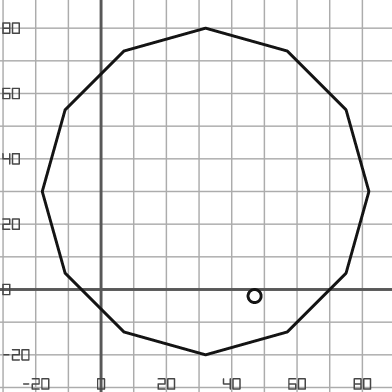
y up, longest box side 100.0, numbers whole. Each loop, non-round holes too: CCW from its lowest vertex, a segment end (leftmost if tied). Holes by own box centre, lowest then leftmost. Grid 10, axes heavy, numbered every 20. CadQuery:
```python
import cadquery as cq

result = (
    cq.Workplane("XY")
    .moveTo(32.0, -20.0)
    .lineTo(57.0, -13.0)
    .lineTo(75.0, 5.0)
    .lineTo(82.0, 30.0)
    .lineTo(75.0, 55.0)
    .lineTo(57.0, 73.0)
    .lineTo(32.0, 80.0)
    .lineTo(7.0, 73.0)
    .lineTo(-11.0, 55.0)
    .lineTo(-18.0, 30.0)
    .lineTo(-11.0, 5.0)
    .lineTo(7.0, -13.0)
    .close()
    .moveTo(47.0, -2.0)
    .circle(2.0)
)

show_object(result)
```